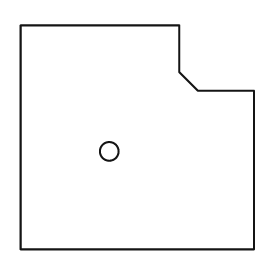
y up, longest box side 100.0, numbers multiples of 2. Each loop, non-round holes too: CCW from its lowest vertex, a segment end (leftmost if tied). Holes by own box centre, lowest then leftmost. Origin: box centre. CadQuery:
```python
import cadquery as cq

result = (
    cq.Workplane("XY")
    .moveTo(-50.0, -48.0)
    .lineTo(50.0, -48.0)
    .lineTo(50.0, 20.0)
    .lineTo(26.0, 20.0)
    .lineTo(18.0, 28.0)
    .lineTo(18.0, 48.0)
    .lineTo(-50.0, 48.0)
    .close()
    .moveTo(-12.0, -6.0)
    .circle(4.0)
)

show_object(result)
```